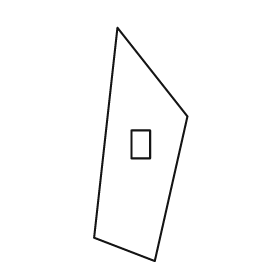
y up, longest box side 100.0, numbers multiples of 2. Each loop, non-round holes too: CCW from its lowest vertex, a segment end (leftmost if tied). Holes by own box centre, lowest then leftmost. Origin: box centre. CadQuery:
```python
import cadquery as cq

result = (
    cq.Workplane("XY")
    .moveTo(6.0, -50.0)
    .lineTo(20.0, 12.0)
    .lineTo(-10.0, 50.0)
    .lineTo(-20.0, -40.0)
    .close()
    .moveTo(-4.0, -6.0)
    .lineTo(4.0, -6.0)
    .lineTo(4.0, 6.0)
    .lineTo(-4.0, 6.0)
    .close()
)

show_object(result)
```